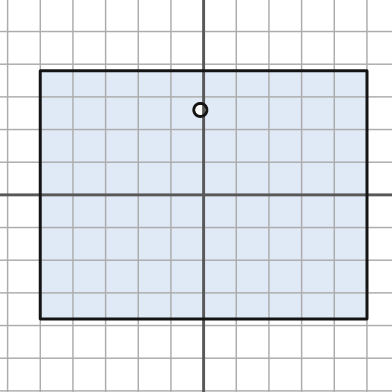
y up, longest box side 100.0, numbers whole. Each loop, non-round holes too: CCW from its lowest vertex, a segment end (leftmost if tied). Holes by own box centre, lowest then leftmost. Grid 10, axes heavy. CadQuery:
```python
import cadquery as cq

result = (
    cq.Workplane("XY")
    .moveTo(-50.0, -38.0)
    .lineTo(50.0, -38.0)
    .lineTo(50.0, 38.0)
    .lineTo(-50.0, 38.0)
    .close()
    .moveTo(-1.0, 26.0)
    .circle(2.0)
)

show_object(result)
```